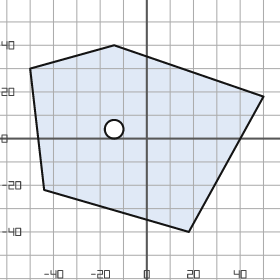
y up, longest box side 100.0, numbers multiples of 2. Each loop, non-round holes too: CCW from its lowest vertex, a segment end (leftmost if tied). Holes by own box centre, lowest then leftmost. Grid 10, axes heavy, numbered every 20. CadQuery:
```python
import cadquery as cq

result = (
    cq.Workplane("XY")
    .moveTo(18.0, -40.0)
    .lineTo(50.0, 18.0)
    .lineTo(-14.0, 40.0)
    .lineTo(-50.0, 30.0)
    .lineTo(-44.0, -22.0)
    .close()
    .moveTo(-14.0, 4.0)
    .circle(4.0)
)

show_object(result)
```